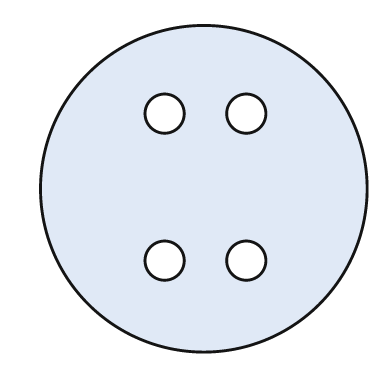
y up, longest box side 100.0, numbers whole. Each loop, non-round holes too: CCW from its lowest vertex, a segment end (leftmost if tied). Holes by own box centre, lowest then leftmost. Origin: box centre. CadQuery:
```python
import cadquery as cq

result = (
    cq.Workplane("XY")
    .moveTo(0.0, 0.0)
    .circle(50.0)
    .moveTo(-12.0, -22.0)
    .circle(6.0)
    .moveTo(13.0, -22.0)
    .circle(6.0)
    .moveTo(-12.0, 23.0)
    .circle(6.0)
    .moveTo(13.0, 23.0)
    .circle(6.0)
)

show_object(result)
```